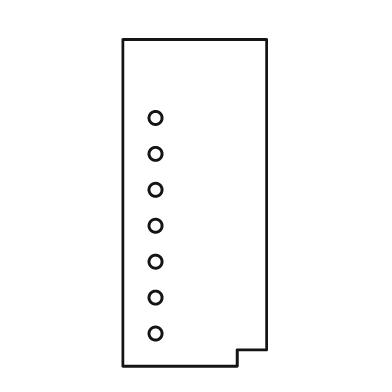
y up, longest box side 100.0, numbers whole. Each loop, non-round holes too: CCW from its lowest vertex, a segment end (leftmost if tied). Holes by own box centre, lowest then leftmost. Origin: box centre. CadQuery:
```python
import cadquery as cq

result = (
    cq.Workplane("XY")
    .moveTo(-22.0, -50.0)
    .lineTo(13.0, -50.0)
    .lineTo(13.0, -45.0)
    .lineTo(22.0, -45.0)
    .lineTo(22.0, 50.0)
    .lineTo(-22.0, 50.0)
    .close()
    .moveTo(-12.0, -40.0)
    .circle(2.0)
    .moveTo(-12.0, -29.0)
    .circle(2.0)
    .moveTo(-12.0, -18.0)
    .circle(2.0)
    .moveTo(-12.0, -7.0)
    .circle(2.0)
    .moveTo(-12.0, 4.0)
    .circle(2.0)
    .moveTo(-12.0, 15.0)
    .circle(2.0)
    .moveTo(-12.0, 26.0)
    .circle(2.0)
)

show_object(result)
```